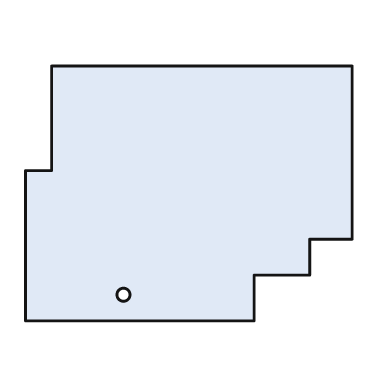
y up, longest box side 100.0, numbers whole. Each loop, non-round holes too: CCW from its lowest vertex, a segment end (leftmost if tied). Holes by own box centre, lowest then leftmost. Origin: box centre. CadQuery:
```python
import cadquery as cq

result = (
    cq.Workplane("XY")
    .moveTo(-50.0, -39.0)
    .lineTo(20.0, -39.0)
    .lineTo(20.0, -25.0)
    .lineTo(37.0, -25.0)
    .lineTo(37.0, -14.0)
    .lineTo(50.0, -14.0)
    .lineTo(50.0, 39.0)
    .lineTo(-42.0, 39.0)
    .lineTo(-42.0, 7.0)
    .lineTo(-50.0, 7.0)
    .close()
    .moveTo(-20.0, -31.0)
    .circle(2.0)
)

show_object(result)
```